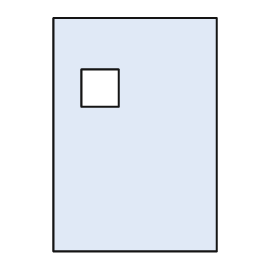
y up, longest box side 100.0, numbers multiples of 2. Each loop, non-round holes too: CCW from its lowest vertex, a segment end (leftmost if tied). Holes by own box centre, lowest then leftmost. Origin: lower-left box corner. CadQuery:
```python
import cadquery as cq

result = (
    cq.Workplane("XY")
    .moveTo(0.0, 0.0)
    .lineTo(70.0, 0.0)
    .lineTo(70.0, 100.0)
    .lineTo(0.0, 100.0)
    .close()
    .moveTo(12.0, 62.0)
    .lineTo(28.0, 62.0)
    .lineTo(28.0, 78.0)
    .lineTo(12.0, 78.0)
    .close()
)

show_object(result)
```